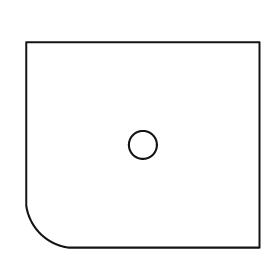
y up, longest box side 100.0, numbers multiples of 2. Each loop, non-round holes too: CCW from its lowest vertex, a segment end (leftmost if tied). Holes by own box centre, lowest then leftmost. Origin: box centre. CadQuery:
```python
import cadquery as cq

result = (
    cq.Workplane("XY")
    .moveTo(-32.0, -44.0)
    .lineTo(50.0, -44.0)
    .lineTo(50.0, 44.0)
    .lineTo(-50.0, 44.0)
    .lineTo(-50.0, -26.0)
    .threePointArc((-44.0, -38.0), (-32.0, -44.0))
    .close()
    .moveTo(0.0, 0.0)
    .circle(6.0)
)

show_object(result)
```